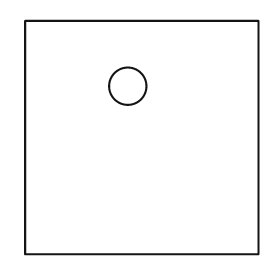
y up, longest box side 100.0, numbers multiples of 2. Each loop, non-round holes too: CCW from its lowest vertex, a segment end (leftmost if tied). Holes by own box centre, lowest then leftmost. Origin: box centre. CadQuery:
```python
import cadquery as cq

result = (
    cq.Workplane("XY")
    .moveTo(-50.0, -50.0)
    .lineTo(50.0, -50.0)
    .lineTo(50.0, 50.0)
    .lineTo(-50.0, 50.0)
    .close()
    .moveTo(-6.0, 22.0)
    .circle(8.0)
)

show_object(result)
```